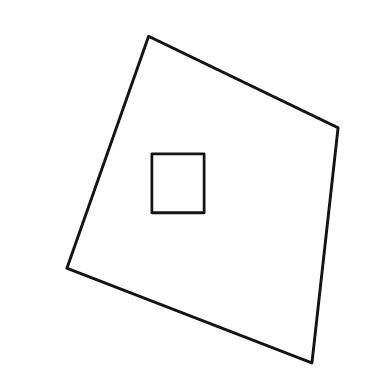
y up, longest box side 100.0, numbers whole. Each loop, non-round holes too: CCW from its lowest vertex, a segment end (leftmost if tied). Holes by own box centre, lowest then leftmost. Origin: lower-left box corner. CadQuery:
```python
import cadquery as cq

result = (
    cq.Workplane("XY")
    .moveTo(75.0, 0.0)
    .lineTo(83.0, 72.0)
    .lineTo(25.0, 100.0)
    .lineTo(0.0, 29.0)
    .close()
    .moveTo(26.0, 46.0)
    .lineTo(42.0, 46.0)
    .lineTo(42.0, 64.0)
    .lineTo(26.0, 64.0)
    .close()
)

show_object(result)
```